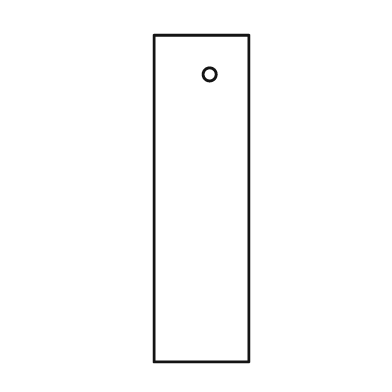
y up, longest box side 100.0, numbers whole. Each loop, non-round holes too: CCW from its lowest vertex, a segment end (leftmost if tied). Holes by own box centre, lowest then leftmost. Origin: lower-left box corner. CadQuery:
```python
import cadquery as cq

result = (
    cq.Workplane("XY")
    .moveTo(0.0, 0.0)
    .lineTo(29.0, 0.0)
    .lineTo(29.0, 100.0)
    .lineTo(0.0, 100.0)
    .close()
    .moveTo(17.0, 88.0)
    .circle(2.0)
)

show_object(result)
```